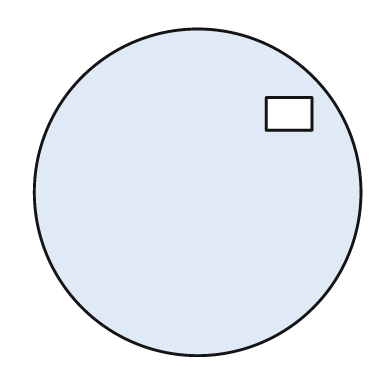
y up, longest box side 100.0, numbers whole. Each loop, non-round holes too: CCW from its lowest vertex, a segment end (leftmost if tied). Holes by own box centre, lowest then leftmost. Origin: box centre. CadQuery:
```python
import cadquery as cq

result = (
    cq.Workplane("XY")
    .moveTo(0.0, 0.0)
    .circle(50.0)
    .moveTo(21.0, 19.0)
    .lineTo(35.0, 19.0)
    .lineTo(35.0, 29.0)
    .lineTo(21.0, 29.0)
    .close()
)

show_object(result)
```